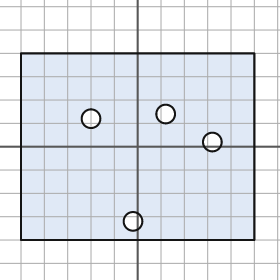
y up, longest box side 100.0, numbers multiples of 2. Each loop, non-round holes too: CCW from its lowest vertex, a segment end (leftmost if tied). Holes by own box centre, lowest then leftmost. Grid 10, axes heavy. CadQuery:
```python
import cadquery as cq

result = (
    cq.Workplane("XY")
    .moveTo(-50.0, -40.0)
    .lineTo(50.0, -40.0)
    .lineTo(50.0, 40.0)
    .lineTo(-50.0, 40.0)
    .close()
    .moveTo(-2.0, -32.0)
    .circle(4.0)
    .moveTo(32.0, 2.0)
    .circle(4.0)
    .moveTo(-20.0, 12.0)
    .circle(4.0)
    .moveTo(12.0, 14.0)
    .circle(4.0)
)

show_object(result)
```